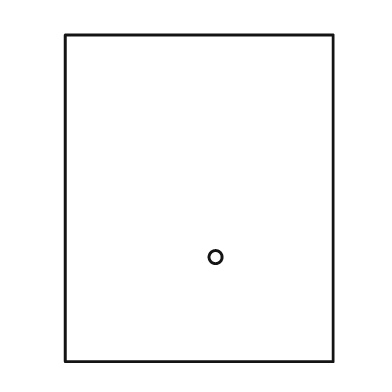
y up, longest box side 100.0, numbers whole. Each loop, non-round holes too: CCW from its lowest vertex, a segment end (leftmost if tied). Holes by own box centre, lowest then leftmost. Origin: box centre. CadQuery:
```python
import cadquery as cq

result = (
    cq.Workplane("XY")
    .moveTo(-41.0, -50.0)
    .lineTo(41.0, -50.0)
    .lineTo(41.0, 50.0)
    .lineTo(-41.0, 50.0)
    .close()
    .moveTo(5.0, -18.0)
    .circle(2.0)
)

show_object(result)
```